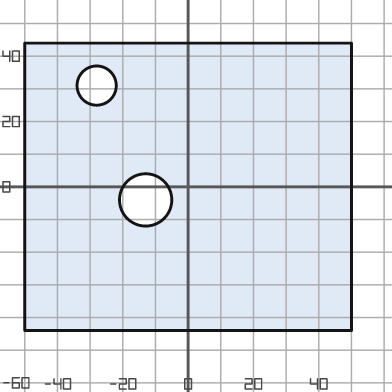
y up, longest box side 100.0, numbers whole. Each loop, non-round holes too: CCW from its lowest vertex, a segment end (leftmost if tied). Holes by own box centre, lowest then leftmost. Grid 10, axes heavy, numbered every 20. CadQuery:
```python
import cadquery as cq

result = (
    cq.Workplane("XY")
    .moveTo(-50.0, -44.0)
    .lineTo(50.0, -44.0)
    .lineTo(50.0, 44.0)
    .lineTo(-50.0, 44.0)
    .close()
    .moveTo(-13.0, -4.0)
    .circle(8.0)
    .moveTo(-28.0, 31.0)
    .circle(6.0)
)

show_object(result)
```